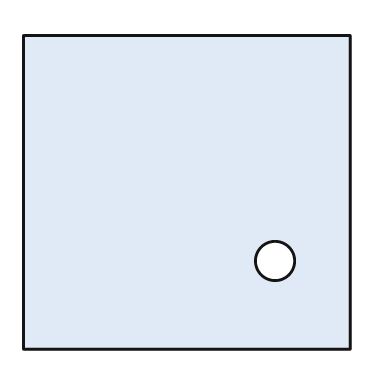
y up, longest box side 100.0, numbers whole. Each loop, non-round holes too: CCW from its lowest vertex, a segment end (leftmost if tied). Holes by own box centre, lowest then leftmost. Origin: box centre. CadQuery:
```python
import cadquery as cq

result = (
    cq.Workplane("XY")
    .moveTo(-50.0, -48.0)
    .lineTo(50.0, -48.0)
    .lineTo(50.0, 48.0)
    .lineTo(-50.0, 48.0)
    .close()
    .moveTo(27.0, -21.0)
    .circle(6.0)
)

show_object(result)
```